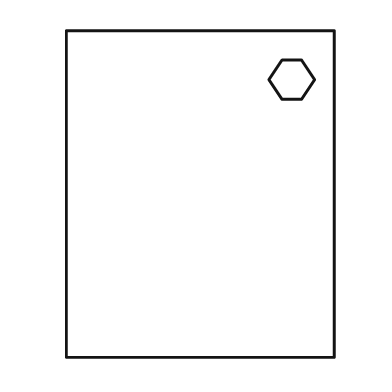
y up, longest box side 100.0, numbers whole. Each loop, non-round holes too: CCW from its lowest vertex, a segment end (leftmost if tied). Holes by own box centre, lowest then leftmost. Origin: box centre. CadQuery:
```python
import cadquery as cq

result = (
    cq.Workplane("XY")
    .moveTo(-41.0, -50.0)
    .lineTo(41.0, -50.0)
    .lineTo(41.0, 50.0)
    .lineTo(-41.0, 50.0)
    .close()
    .moveTo(25.0, 29.0)
    .lineTo(31.0, 29.0)
    .lineTo(35.0, 35.0)
    .lineTo(31.0, 41.0)
    .lineTo(25.0, 41.0)
    .lineTo(21.0, 35.0)
    .close()
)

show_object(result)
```